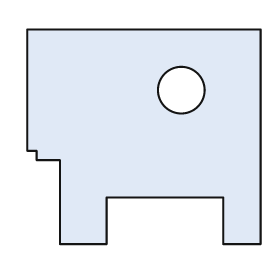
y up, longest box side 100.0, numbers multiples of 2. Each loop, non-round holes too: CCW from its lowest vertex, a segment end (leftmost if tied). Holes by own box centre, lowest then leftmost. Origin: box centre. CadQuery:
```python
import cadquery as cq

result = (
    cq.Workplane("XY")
    .moveTo(-36.0, -46.0)
    .lineTo(-16.0, -46.0)
    .lineTo(-16.0, -26.0)
    .lineTo(34.0, -26.0)
    .lineTo(34.0, -46.0)
    .lineTo(50.0, -46.0)
    .lineTo(50.0, 46.0)
    .lineTo(-50.0, 46.0)
    .lineTo(-50.0, -6.0)
    .lineTo(-46.0, -6.0)
    .lineTo(-46.0, -10.0)
    .lineTo(-36.0, -10.0)
    .close()
    .moveTo(16.0, 20.0)
    .circle(10.0)
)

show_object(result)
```